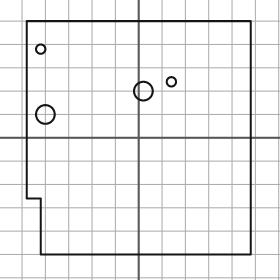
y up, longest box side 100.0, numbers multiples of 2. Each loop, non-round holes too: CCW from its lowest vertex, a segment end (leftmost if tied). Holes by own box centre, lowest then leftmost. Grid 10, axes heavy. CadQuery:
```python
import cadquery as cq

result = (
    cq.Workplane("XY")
    .moveTo(-42.0, -50.0)
    .lineTo(48.0, -50.0)
    .lineTo(48.0, 50.0)
    .lineTo(-48.0, 50.0)
    .lineTo(-48.0, -26.0)
    .lineTo(-42.0, -26.0)
    .close()
    .moveTo(-40.0, 10.0)
    .circle(4.0)
    .moveTo(2.0, 20.0)
    .circle(4.0)
    .moveTo(14.0, 24.0)
    .circle(2.0)
    .moveTo(-42.0, 38.0)
    .circle(2.0)
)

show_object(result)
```